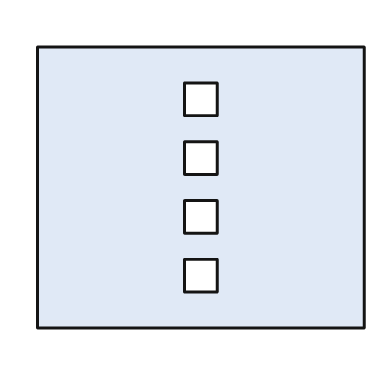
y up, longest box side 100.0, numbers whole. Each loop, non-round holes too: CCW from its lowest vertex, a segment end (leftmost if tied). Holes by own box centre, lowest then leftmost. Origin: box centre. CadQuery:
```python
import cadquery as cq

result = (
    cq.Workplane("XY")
    .moveTo(-50.0, -43.0)
    .lineTo(50.0, -43.0)
    .lineTo(50.0, 43.0)
    .lineTo(-50.0, 43.0)
    .close()
    .moveTo(-5.0, -32.0)
    .lineTo(5.0, -32.0)
    .lineTo(5.0, -22.0)
    .lineTo(-5.0, -22.0)
    .close()
    .moveTo(-5.0, -14.0)
    .lineTo(5.0, -14.0)
    .lineTo(5.0, -4.0)
    .lineTo(-5.0, -4.0)
    .close()
    .moveTo(-5.0, 4.0)
    .lineTo(5.0, 4.0)
    .lineTo(5.0, 14.0)
    .lineTo(-5.0, 14.0)
    .close()
    .moveTo(-5.0, 22.0)
    .lineTo(5.0, 22.0)
    .lineTo(5.0, 32.0)
    .lineTo(-5.0, 32.0)
    .close()
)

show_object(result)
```